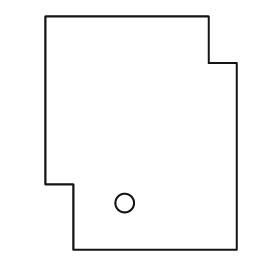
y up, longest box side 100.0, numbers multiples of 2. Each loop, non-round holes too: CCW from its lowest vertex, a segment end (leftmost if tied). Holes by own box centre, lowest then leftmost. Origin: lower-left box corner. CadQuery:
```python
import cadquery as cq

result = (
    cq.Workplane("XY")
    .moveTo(12.0, 0.0)
    .lineTo(82.0, 0.0)
    .lineTo(82.0, 80.0)
    .lineTo(70.0, 80.0)
    .lineTo(70.0, 100.0)
    .lineTo(0.0, 100.0)
    .lineTo(0.0, 28.0)
    .lineTo(12.0, 28.0)
    .close()
    .moveTo(34.0, 20.0)
    .circle(4.0)
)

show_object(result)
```